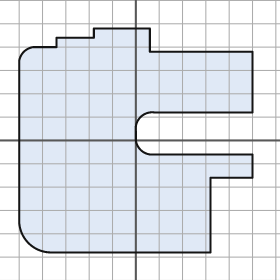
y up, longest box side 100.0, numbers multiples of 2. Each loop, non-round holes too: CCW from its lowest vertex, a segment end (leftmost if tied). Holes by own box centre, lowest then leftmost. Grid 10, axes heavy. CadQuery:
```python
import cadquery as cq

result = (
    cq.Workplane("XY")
    .moveTo(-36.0, -48.0)
    .lineTo(32.0, -48.0)
    .lineTo(32.0, -16.0)
    .lineTo(50.0, -16.0)
    .lineTo(50.0, -6.0)
    .lineTo(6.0, -6.0)
    .threePointArc((2.0, -4.0), (0.0, 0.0))
    .lineTo(0.0, 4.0)
    .threePointArc((2.0, 10.0), (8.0, 12.0))
    .lineTo(50.0, 12.0)
    .lineTo(50.0, 38.0)
    .lineTo(6.0, 38.0)
    .lineTo(6.0, 48.0)
    .lineTo(-18.0, 48.0)
    .lineTo(-18.0, 44.0)
    .lineTo(-34.0, 44.0)
    .lineTo(-34.0, 40.0)
    .lineTo(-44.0, 40.0)
    .threePointArc((-48.0, 38.0), (-50.0, 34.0))
    .lineTo(-50.0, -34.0)
    .threePointArc((-46.0, -44.0), (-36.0, -48.0))
    .close()
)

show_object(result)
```